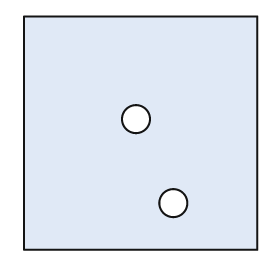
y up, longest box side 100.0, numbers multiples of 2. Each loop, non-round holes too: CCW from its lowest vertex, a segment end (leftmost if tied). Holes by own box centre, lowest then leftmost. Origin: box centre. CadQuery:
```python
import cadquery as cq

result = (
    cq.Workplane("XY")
    .moveTo(-50.0, -50.0)
    .lineTo(50.0, -50.0)
    .lineTo(50.0, 50.0)
    .lineTo(-50.0, 50.0)
    .close()
    .moveTo(14.0, -30.0)
    .circle(6.0)
    .moveTo(-2.0, 6.0)
    .circle(6.0)
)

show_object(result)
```